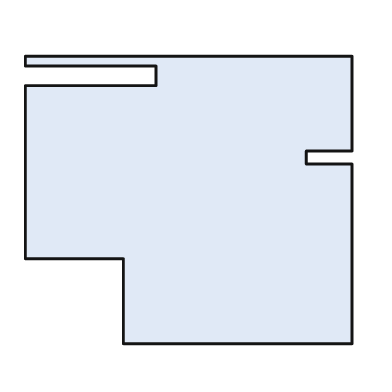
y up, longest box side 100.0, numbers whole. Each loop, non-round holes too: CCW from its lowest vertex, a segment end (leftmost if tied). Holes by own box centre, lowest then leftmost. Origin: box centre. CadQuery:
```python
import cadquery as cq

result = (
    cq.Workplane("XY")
    .moveTo(-20.0, -44.0)
    .lineTo(50.0, -44.0)
    .lineTo(50.0, 11.0)
    .lineTo(36.0, 11.0)
    .lineTo(36.0, 15.0)
    .lineTo(50.0, 15.0)
    .lineTo(50.0, 44.0)
    .lineTo(-50.0, 44.0)
    .lineTo(-50.0, 41.0)
    .lineTo(-10.0, 41.0)
    .lineTo(-10.0, 35.0)
    .lineTo(-50.0, 35.0)
    .lineTo(-50.0, -18.0)
    .lineTo(-20.0, -18.0)
    .close()
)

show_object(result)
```